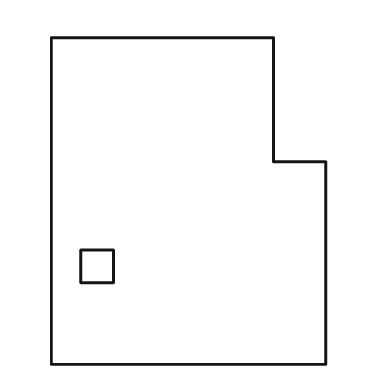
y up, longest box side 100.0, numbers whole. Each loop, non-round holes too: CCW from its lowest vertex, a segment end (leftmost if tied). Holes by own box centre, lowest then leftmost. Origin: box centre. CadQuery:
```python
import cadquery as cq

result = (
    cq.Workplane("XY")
    .moveTo(-42.0, -50.0)
    .lineTo(42.0, -50.0)
    .lineTo(42.0, 12.0)
    .lineTo(26.0, 12.0)
    .lineTo(26.0, 50.0)
    .lineTo(-42.0, 50.0)
    .close()
    .moveTo(-33.0, -25.0)
    .lineTo(-23.0, -25.0)
    .lineTo(-23.0, -15.0)
    .lineTo(-33.0, -15.0)
    .close()
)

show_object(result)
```